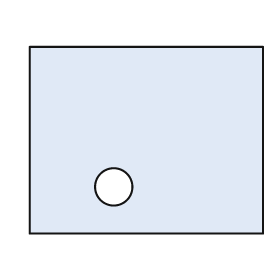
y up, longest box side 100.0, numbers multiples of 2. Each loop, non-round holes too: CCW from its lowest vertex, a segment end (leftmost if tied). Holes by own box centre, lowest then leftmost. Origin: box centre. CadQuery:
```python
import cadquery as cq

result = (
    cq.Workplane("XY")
    .moveTo(-50.0, -40.0)
    .lineTo(50.0, -40.0)
    .lineTo(50.0, 40.0)
    .lineTo(-50.0, 40.0)
    .close()
    .moveTo(-14.0, -20.0)
    .circle(8.0)
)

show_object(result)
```